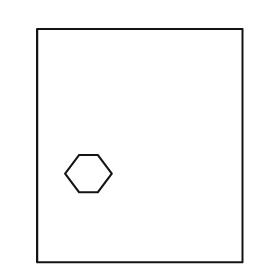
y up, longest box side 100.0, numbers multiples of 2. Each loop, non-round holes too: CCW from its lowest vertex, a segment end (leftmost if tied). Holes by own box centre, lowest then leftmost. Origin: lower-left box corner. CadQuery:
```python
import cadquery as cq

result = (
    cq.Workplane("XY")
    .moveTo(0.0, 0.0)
    .lineTo(88.0, 0.0)
    .lineTo(88.0, 100.0)
    .lineTo(0.0, 100.0)
    .close()
    .moveTo(18.0, 30.0)
    .lineTo(26.0, 30.0)
    .lineTo(32.0, 38.0)
    .lineTo(26.0, 46.0)
    .lineTo(18.0, 46.0)
    .lineTo(12.0, 38.0)
    .close()
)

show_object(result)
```